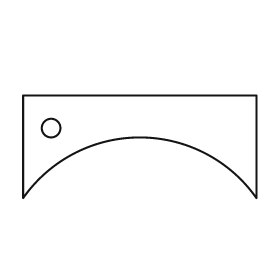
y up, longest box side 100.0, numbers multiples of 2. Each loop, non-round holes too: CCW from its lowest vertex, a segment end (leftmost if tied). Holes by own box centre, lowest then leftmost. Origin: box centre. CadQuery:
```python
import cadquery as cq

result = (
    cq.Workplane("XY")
    .moveTo(-50.0, -22.0)
    .threePointArc((0.0, 4.0), (50.0, -22.0))
    .lineTo(50.0, 22.0)
    .lineTo(-50.0, 22.0)
    .close()
    .moveTo(-38.0, 8.0)
    .circle(4.0)
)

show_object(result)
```